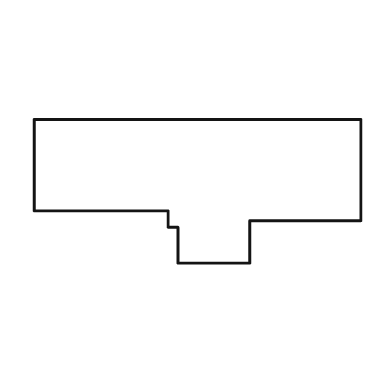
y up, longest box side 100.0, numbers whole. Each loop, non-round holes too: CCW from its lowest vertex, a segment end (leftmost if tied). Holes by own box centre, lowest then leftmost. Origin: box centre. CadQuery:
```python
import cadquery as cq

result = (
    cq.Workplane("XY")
    .moveTo(-6.0, -22.0)
    .lineTo(16.0, -22.0)
    .lineTo(16.0, -9.0)
    .lineTo(50.0, -9.0)
    .lineTo(50.0, 22.0)
    .lineTo(-50.0, 22.0)
    .lineTo(-50.0, -6.0)
    .lineTo(-9.0, -6.0)
    .lineTo(-9.0, -11.0)
    .lineTo(-6.0, -11.0)
    .close()
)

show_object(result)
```